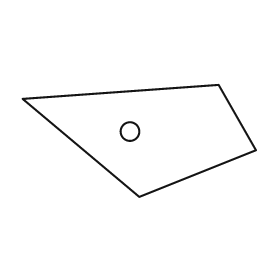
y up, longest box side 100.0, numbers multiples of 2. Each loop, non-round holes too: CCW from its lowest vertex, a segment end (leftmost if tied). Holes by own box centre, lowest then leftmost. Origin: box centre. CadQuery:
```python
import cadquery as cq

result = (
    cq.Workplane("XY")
    .moveTo(0.0, -24.0)
    .lineTo(50.0, -4.0)
    .lineTo(34.0, 24.0)
    .lineTo(-50.0, 18.0)
    .close()
    .moveTo(-4.0, 4.0)
    .circle(4.0)
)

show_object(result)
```